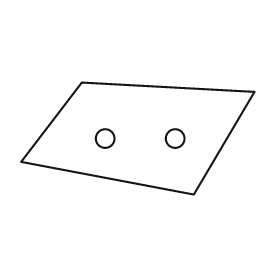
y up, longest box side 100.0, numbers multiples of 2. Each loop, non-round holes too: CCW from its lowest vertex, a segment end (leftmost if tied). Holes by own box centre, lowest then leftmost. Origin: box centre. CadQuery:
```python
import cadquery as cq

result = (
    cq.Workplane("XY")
    .moveTo(24.0, -24.0)
    .lineTo(50.0, 20.0)
    .lineTo(-24.0, 24.0)
    .lineTo(-50.0, -10.0)
    .close()
    .moveTo(-14.0, 0.0)
    .circle(4.0)
    .moveTo(16.0, 0.0)
    .circle(4.0)
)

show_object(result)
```